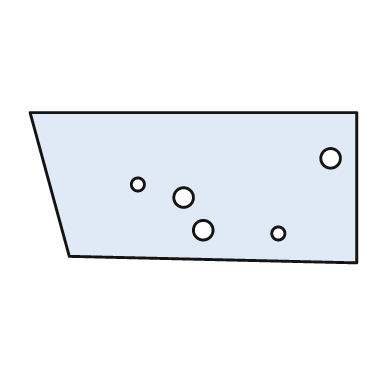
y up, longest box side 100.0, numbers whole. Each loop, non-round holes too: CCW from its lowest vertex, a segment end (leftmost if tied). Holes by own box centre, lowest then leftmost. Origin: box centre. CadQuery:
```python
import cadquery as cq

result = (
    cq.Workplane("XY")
    .moveTo(50.0, -23.0)
    .lineTo(50.0, 23.0)
    .lineTo(-50.0, 23.0)
    .lineTo(-38.0, -21.0)
    .close()
    .moveTo(26.0, -14.0)
    .circle(2.0)
    .moveTo(3.0, -13.0)
    .circle(3.0)
    .moveTo(-3.0, -3.0)
    .circle(3.0)
    .moveTo(-17.0, 1.0)
    .circle(2.0)
    .moveTo(42.0, 9.0)
    .circle(3.0)
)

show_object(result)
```